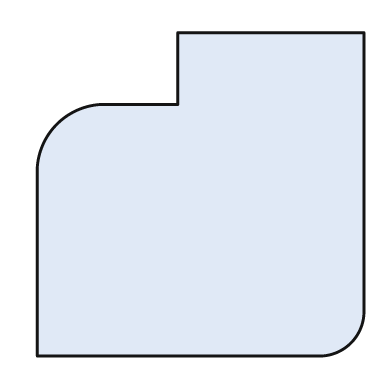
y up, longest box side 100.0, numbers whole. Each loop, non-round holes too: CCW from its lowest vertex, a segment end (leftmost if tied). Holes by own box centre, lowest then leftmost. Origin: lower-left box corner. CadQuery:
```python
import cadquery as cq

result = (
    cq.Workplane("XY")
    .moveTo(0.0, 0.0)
    .lineTo(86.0, 0.0)
    .threePointArc((96.0, 4.0), (100.0, 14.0))
    .lineTo(100.0, 99.0)
    .lineTo(43.0, 99.0)
    .lineTo(43.0, 77.0)
    .lineTo(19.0, 77.0)
    .threePointArc((6.0, 71.0), (0.0, 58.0))
    .close()
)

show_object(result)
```